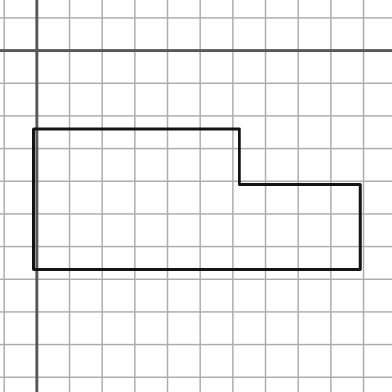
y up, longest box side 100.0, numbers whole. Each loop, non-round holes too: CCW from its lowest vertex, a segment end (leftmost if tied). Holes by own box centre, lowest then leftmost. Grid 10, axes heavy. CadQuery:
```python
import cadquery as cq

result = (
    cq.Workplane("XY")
    .moveTo(-1.0, -67.0)
    .lineTo(99.0, -67.0)
    .lineTo(99.0, -41.0)
    .lineTo(62.0, -41.0)
    .lineTo(62.0, -24.0)
    .lineTo(-1.0, -24.0)
    .close()
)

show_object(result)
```